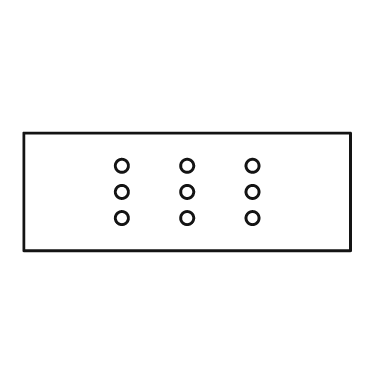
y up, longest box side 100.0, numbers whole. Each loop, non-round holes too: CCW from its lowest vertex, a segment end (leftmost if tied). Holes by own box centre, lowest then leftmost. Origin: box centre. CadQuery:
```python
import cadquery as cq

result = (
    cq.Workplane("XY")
    .moveTo(-50.0, -18.0)
    .lineTo(50.0, -18.0)
    .lineTo(50.0, 18.0)
    .lineTo(-50.0, 18.0)
    .close()
    .moveTo(-20.0, -8.0)
    .circle(2.0)
    .moveTo(0.0, -8.0)
    .circle(2.0)
    .moveTo(20.0, -8.0)
    .circle(2.0)
    .moveTo(-20.0, 0.0)
    .circle(2.0)
    .moveTo(0.0, 0.0)
    .circle(2.0)
    .moveTo(20.0, 0.0)
    .circle(2.0)
    .moveTo(-20.0, 8.0)
    .circle(2.0)
    .moveTo(0.0, 8.0)
    .circle(2.0)
    .moveTo(20.0, 8.0)
    .circle(2.0)
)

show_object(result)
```